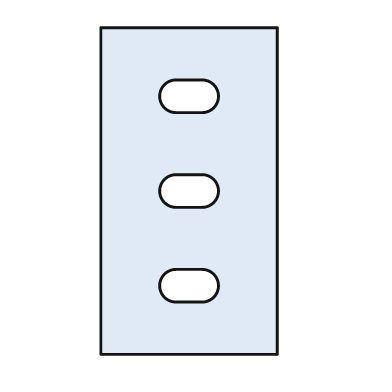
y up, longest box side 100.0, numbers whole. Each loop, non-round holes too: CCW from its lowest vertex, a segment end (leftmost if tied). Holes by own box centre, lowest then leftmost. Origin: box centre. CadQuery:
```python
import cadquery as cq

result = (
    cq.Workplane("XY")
    .moveTo(-27.0, -50.0)
    .lineTo(27.0, -50.0)
    .lineTo(27.0, 50.0)
    .lineTo(-27.0, 50.0)
    .close()
    .moveTo(-4.0, -34.0)
    .lineTo(4.0, -34.0)
    .threePointArc((9.0, -29.0), (4.0, -24.0))
    .lineTo(-4.0, -24.0)
    .threePointArc((-9.0, -29.0), (-4.0, -34.0))
    .close()
    .moveTo(-4.0, -5.0)
    .lineTo(4.0, -5.0)
    .threePointArc((9.0, 0.0), (4.0, 5.0))
    .lineTo(-4.0, 5.0)
    .threePointArc((-9.0, 0.0), (-4.0, -5.0))
    .close()
    .moveTo(-4.0, 24.0)
    .lineTo(4.0, 24.0)
    .threePointArc((9.0, 29.0), (4.0, 34.0))
    .lineTo(-4.0, 34.0)
    .threePointArc((-9.0, 29.0), (-4.0, 24.0))
    .close()
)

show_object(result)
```